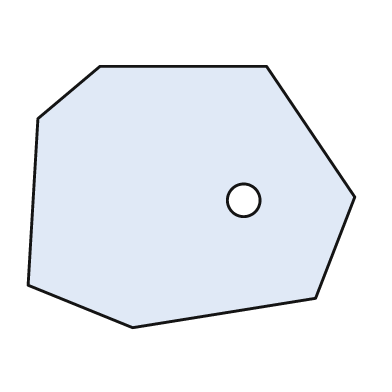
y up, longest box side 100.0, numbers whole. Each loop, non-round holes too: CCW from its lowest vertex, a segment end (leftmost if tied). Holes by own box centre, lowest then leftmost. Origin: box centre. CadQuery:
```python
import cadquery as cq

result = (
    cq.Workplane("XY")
    .moveTo(-18.0, -40.0)
    .lineTo(38.0, -31.0)
    .lineTo(50.0, 0.0)
    .lineTo(23.0, 40.0)
    .lineTo(-28.0, 40.0)
    .lineTo(-47.0, 24.0)
    .lineTo(-50.0, -27.0)
    .close()
    .moveTo(16.0, -1.0)
    .circle(5.0)
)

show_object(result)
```